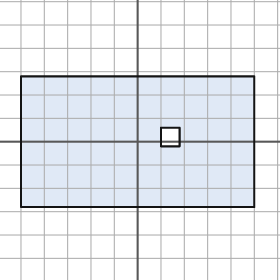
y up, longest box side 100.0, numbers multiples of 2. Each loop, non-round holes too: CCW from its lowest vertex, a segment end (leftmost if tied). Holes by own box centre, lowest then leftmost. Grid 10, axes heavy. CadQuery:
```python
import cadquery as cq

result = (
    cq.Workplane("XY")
    .moveTo(-50.0, -28.0)
    .lineTo(50.0, -28.0)
    .lineTo(50.0, 28.0)
    .lineTo(-50.0, 28.0)
    .close()
    .moveTo(10.0, -2.0)
    .lineTo(18.0, -2.0)
    .lineTo(18.0, 6.0)
    .lineTo(10.0, 6.0)
    .close()
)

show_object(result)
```